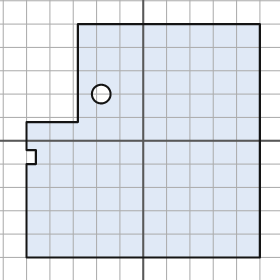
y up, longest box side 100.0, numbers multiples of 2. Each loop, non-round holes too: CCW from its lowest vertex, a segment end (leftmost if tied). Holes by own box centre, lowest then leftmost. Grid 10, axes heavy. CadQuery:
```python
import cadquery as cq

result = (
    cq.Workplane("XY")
    .moveTo(-50.0, -50.0)
    .lineTo(50.0, -50.0)
    .lineTo(50.0, 50.0)
    .lineTo(-28.0, 50.0)
    .lineTo(-28.0, 8.0)
    .lineTo(-50.0, 8.0)
    .lineTo(-50.0, -4.0)
    .lineTo(-46.0, -4.0)
    .lineTo(-46.0, -10.0)
    .lineTo(-50.0, -10.0)
    .close()
    .moveTo(-18.0, 20.0)
    .circle(4.0)
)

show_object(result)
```